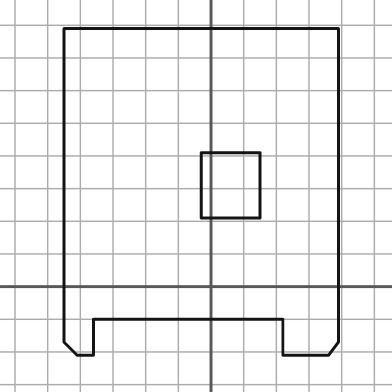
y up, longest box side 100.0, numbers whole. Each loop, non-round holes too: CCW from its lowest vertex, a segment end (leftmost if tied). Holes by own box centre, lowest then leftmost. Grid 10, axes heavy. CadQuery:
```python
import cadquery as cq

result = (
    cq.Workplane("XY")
    .moveTo(-41.0, -21.0)
    .lineTo(-36.0, -21.0)
    .lineTo(-36.0, -10.0)
    .lineTo(22.0, -10.0)
    .lineTo(22.0, -21.0)
    .lineTo(36.0, -21.0)
    .lineTo(39.0, -17.0)
    .lineTo(39.0, 79.0)
    .lineTo(-45.0, 79.0)
    .lineTo(-45.0, -17.0)
    .close()
    .moveTo(-3.0, 21.0)
    .lineTo(15.0, 21.0)
    .lineTo(15.0, 41.0)
    .lineTo(-3.0, 41.0)
    .close()
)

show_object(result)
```